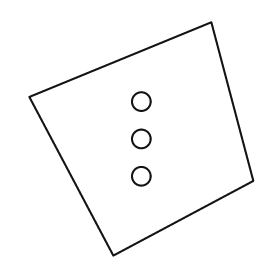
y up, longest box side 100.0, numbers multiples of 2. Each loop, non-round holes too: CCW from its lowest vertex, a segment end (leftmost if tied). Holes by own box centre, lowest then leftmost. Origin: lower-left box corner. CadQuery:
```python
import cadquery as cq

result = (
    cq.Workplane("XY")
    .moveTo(36.0, 0.0)
    .lineTo(96.0, 32.0)
    .lineTo(78.0, 100.0)
    .lineTo(0.0, 68.0)
    .close()
    .moveTo(48.0, 34.0)
    .circle(4.0)
    .moveTo(48.0, 50.0)
    .circle(4.0)
    .moveTo(48.0, 66.0)
    .circle(4.0)
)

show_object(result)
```